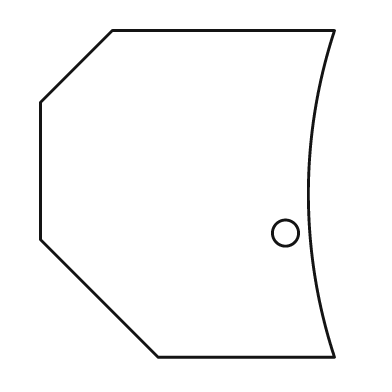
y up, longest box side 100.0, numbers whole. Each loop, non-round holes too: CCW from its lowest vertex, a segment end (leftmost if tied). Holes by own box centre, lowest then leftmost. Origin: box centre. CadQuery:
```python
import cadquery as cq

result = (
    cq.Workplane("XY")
    .moveTo(-9.0, -50.0)
    .lineTo(45.0, -50.0)
    .threePointArc((37.0, 0.0), (45.0, 50.0))
    .lineTo(-23.0, 50.0)
    .lineTo(-45.0, 28.0)
    .lineTo(-45.0, -14.0)
    .close()
    .moveTo(30.0, -12.0)
    .circle(4.0)
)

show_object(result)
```